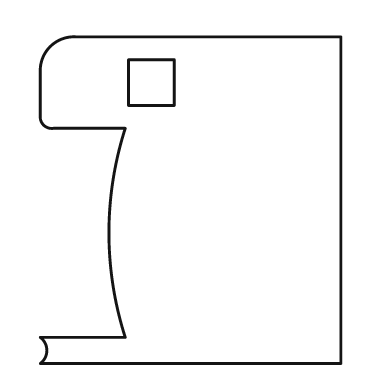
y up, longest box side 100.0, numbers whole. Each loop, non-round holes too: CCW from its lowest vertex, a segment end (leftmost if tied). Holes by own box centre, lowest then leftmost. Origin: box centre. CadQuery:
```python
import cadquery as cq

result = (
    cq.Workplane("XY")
    .moveTo(-46.0, -50.0)
    .lineTo(46.0, -50.0)
    .lineTo(46.0, 50.0)
    .lineTo(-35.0, 50.0)
    .threePointArc((-43.0, 47.0), (-46.0, 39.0))
    .lineTo(-46.0, 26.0)
    .threePointArc((-45.0, 23.0), (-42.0, 22.0))
    .lineTo(-20.0, 22.0)
    .threePointArc((-25.0, -10.0), (-20.0, -42.0))
    .lineTo(-46.0, -42.0)
    .threePointArc((-44.0, -46.0), (-46.0, -50.0))
    .close()
    .moveTo(-19.0, 29.0)
    .lineTo(-5.0, 29.0)
    .lineTo(-5.0, 43.0)
    .lineTo(-19.0, 43.0)
    .close()
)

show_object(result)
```